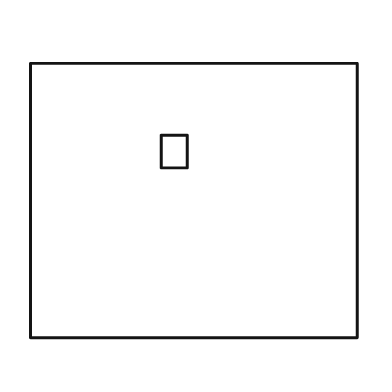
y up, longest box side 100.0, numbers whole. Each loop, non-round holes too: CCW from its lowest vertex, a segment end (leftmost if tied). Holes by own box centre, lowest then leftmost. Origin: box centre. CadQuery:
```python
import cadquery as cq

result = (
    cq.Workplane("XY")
    .moveTo(-50.0, -42.0)
    .lineTo(50.0, -42.0)
    .lineTo(50.0, 42.0)
    .lineTo(-50.0, 42.0)
    .close()
    .moveTo(-10.0, 10.0)
    .lineTo(-2.0, 10.0)
    .lineTo(-2.0, 20.0)
    .lineTo(-10.0, 20.0)
    .close()
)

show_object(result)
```